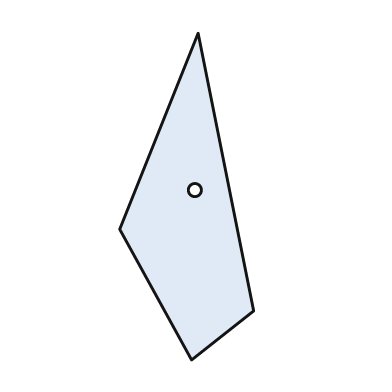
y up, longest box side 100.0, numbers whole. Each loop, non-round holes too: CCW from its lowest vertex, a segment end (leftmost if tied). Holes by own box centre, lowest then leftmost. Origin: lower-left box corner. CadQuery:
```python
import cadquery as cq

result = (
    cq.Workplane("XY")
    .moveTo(22.0, 0.0)
    .lineTo(41.0, 15.0)
    .lineTo(24.0, 100.0)
    .lineTo(0.0, 40.0)
    .close()
    .moveTo(23.0, 52.0)
    .circle(2.0)
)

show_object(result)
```